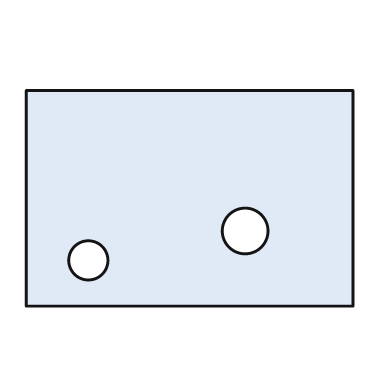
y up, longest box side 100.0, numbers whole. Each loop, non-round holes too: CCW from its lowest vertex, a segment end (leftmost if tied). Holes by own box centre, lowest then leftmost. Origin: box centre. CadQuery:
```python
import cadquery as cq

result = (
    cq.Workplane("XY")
    .moveTo(-50.0, -33.0)
    .lineTo(50.0, -33.0)
    .lineTo(50.0, 33.0)
    .lineTo(-50.0, 33.0)
    .close()
    .moveTo(-31.0, -19.0)
    .circle(6.0)
    .moveTo(17.0, -10.0)
    .circle(7.0)
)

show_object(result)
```